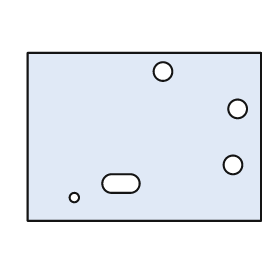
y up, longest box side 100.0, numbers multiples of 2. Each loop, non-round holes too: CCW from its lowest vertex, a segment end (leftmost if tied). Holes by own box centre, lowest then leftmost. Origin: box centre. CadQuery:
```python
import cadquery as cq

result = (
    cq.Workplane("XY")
    .moveTo(-50.0, -36.0)
    .lineTo(50.0, -36.0)
    .lineTo(50.0, 36.0)
    .lineTo(-50.0, 36.0)
    .close()
    .moveTo(-30.0, -26.0)
    .circle(2.0)
    .moveTo(-14.0, -24.0)
    .lineTo(-6.0, -24.0)
    .threePointArc((-2.0, -20.0), (-6.0, -16.0))
    .lineTo(-14.0, -16.0)
    .threePointArc((-18.0, -20.0), (-14.0, -24.0))
    .close()
    .moveTo(38.0, -12.0)
    .circle(4.0)
    .moveTo(40.0, 12.0)
    .circle(4.0)
    .moveTo(8.0, 28.0)
    .circle(4.0)
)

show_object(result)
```